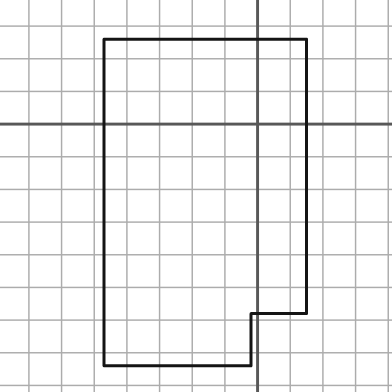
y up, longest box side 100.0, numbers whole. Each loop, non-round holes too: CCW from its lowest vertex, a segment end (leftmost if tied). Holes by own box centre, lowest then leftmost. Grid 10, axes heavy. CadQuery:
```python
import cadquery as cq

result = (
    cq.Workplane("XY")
    .moveTo(-47.0, -74.0)
    .lineTo(-2.0, -74.0)
    .lineTo(-2.0, -58.0)
    .lineTo(15.0, -58.0)
    .lineTo(15.0, 26.0)
    .lineTo(-47.0, 26.0)
    .close()
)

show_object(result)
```